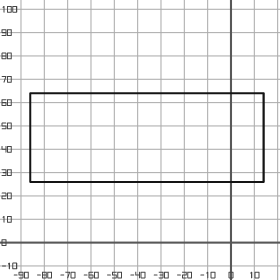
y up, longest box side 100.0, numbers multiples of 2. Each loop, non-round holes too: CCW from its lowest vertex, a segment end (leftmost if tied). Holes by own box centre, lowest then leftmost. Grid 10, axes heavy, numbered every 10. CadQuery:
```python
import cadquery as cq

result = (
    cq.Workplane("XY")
    .moveTo(-86.0, 26.0)
    .lineTo(14.0, 26.0)
    .lineTo(14.0, 64.0)
    .lineTo(-86.0, 64.0)
    .close()
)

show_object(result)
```